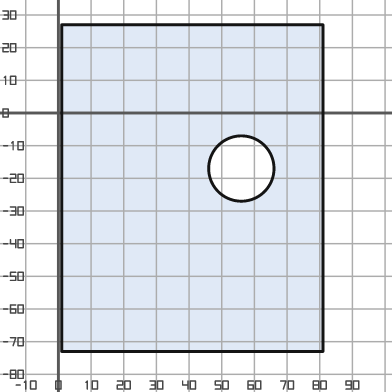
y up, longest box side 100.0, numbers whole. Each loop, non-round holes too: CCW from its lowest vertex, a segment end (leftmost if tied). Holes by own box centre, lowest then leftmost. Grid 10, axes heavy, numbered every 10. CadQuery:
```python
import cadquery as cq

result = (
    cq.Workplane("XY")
    .moveTo(1.0, -73.0)
    .lineTo(81.0, -73.0)
    .lineTo(81.0, 27.0)
    .lineTo(1.0, 27.0)
    .close()
    .moveTo(56.0, -17.0)
    .circle(10.0)
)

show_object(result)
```